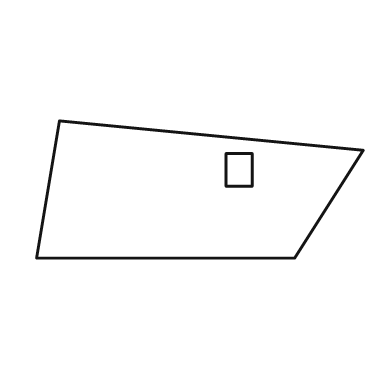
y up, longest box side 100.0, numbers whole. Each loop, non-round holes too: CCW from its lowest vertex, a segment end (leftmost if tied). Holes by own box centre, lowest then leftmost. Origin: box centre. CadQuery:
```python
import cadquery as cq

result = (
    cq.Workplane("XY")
    .moveTo(-50.0, -21.0)
    .lineTo(29.0, -21.0)
    .lineTo(50.0, 12.0)
    .lineTo(-43.0, 21.0)
    .close()
    .moveTo(8.0, 1.0)
    .lineTo(16.0, 1.0)
    .lineTo(16.0, 11.0)
    .lineTo(8.0, 11.0)
    .close()
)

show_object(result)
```